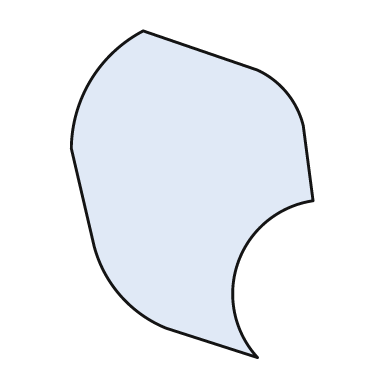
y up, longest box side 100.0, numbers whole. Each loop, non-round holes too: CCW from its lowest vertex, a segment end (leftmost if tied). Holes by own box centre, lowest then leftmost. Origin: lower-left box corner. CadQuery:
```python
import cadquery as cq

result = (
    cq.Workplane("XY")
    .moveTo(57.0, 0.0)
    .threePointArc((51.0, 29.0), (74.0, 48.0))
    .lineTo(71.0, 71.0)
    .threePointArc((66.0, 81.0), (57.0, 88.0))
    .lineTo(22.0, 100.0)
    .threePointArc((6.0, 85.0), (0.0, 64.0))
    .lineTo(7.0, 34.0)
    .threePointArc((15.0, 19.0), (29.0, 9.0))
    .close()
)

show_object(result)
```